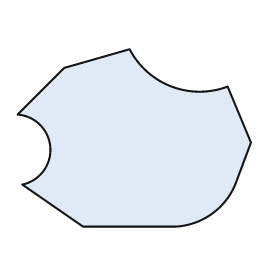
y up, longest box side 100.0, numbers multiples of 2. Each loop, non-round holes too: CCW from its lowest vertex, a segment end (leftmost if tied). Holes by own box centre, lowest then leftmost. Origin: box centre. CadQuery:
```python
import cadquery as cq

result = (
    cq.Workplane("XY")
    .moveTo(-22.0, -38.0)
    .lineTo(18.0, -38.0)
    .threePointArc((34.0, -32.0), (44.0, -18.0))
    .lineTo(50.0, -2.0)
    .lineTo(40.0, 22.0)
    .threePointArc((16.0, 22.0), (-2.0, 38.0))
    .lineTo(-30.0, 30.0)
    .lineTo(-50.0, 10.0)
    .threePointArc((-36.0, -4.0), (-48.0, -20.0))
    .close()
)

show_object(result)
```